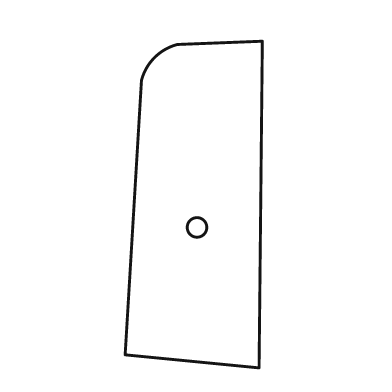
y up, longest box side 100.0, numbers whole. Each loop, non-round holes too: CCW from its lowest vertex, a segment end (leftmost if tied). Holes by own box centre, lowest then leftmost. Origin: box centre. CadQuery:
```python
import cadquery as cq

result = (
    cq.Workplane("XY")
    .moveTo(20.0, -50.0)
    .lineTo(21.0, 50.0)
    .lineTo(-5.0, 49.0)
    .threePointArc((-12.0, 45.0), (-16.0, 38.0))
    .lineTo(-21.0, -46.0)
    .close()
    .moveTo(1.0, -7.0)
    .circle(3.0)
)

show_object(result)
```